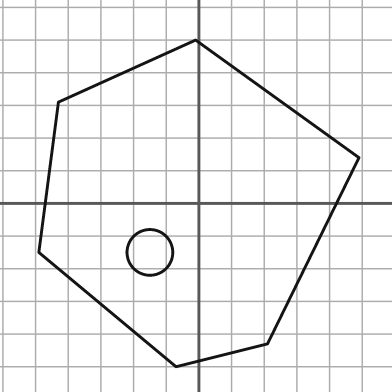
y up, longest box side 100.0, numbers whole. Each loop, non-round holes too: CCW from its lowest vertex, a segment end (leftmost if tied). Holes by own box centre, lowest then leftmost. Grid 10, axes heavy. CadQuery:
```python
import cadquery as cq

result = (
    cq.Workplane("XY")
    .moveTo(-7.0, -50.0)
    .lineTo(21.0, -43.0)
    .lineTo(49.0, 14.0)
    .lineTo(-1.0, 50.0)
    .lineTo(-43.0, 31.0)
    .lineTo(-49.0, -15.0)
    .close()
    .moveTo(-15.0, -15.0)
    .circle(7.0)
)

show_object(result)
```